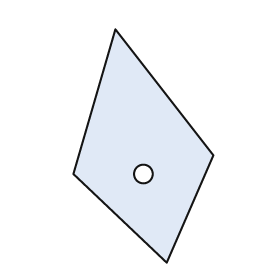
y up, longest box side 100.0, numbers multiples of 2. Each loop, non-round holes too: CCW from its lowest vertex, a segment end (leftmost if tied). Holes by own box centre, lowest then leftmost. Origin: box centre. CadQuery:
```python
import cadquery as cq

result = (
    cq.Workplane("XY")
    .moveTo(10.0, -50.0)
    .lineTo(30.0, -4.0)
    .lineTo(-12.0, 50.0)
    .lineTo(-30.0, -12.0)
    .close()
    .moveTo(0.0, -12.0)
    .circle(4.0)
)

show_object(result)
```